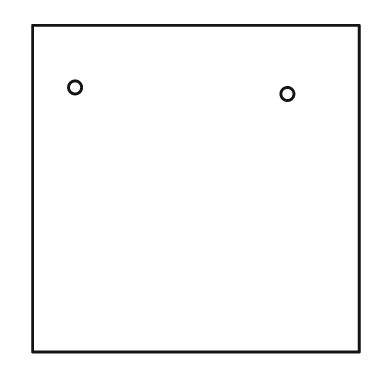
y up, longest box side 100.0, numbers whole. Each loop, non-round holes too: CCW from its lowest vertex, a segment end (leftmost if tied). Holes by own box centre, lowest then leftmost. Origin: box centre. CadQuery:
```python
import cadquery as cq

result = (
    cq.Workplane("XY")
    .moveTo(-50.0, -50.0)
    .lineTo(50.0, -50.0)
    .lineTo(50.0, 50.0)
    .lineTo(-50.0, 50.0)
    .close()
    .moveTo(28.0, 29.0)
    .circle(2.0)
    .moveTo(-37.0, 31.0)
    .circle(2.0)
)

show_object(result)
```